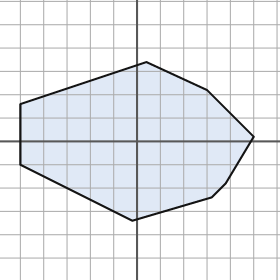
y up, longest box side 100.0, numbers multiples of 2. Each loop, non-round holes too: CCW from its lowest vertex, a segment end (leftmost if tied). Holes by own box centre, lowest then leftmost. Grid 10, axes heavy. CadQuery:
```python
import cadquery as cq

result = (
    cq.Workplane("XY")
    .moveTo(-2.0, -34.0)
    .lineTo(32.0, -24.0)
    .lineTo(38.0, -18.0)
    .lineTo(50.0, 2.0)
    .lineTo(30.0, 22.0)
    .lineTo(4.0, 34.0)
    .lineTo(-50.0, 16.0)
    .lineTo(-50.0, -10.0)
    .close()
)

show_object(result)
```